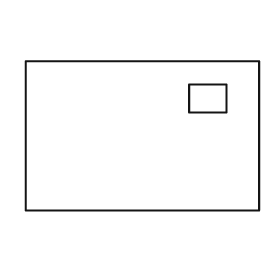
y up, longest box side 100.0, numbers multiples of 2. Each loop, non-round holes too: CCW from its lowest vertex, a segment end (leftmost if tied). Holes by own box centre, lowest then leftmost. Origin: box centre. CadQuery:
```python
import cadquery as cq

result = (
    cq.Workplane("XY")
    .moveTo(-50.0, -32.0)
    .lineTo(50.0, -32.0)
    .lineTo(50.0, 32.0)
    .lineTo(-50.0, 32.0)
    .close()
    .moveTo(20.0, 10.0)
    .lineTo(36.0, 10.0)
    .lineTo(36.0, 22.0)
    .lineTo(20.0, 22.0)
    .close()
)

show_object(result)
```